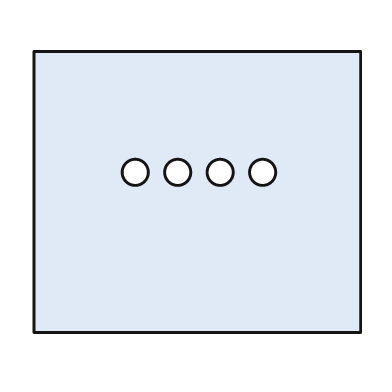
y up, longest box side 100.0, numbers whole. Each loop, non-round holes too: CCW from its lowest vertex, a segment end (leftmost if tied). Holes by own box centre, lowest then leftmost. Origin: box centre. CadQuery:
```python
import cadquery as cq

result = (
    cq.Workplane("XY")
    .moveTo(-50.0, -43.0)
    .lineTo(50.0, -43.0)
    .lineTo(50.0, 43.0)
    .lineTo(-50.0, 43.0)
    .close()
    .moveTo(-19.0, 6.0)
    .circle(4.0)
    .moveTo(-6.0, 6.0)
    .circle(4.0)
    .moveTo(7.0, 6.0)
    .circle(4.0)
    .moveTo(20.0, 6.0)
    .circle(4.0)
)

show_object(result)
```